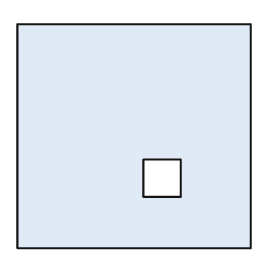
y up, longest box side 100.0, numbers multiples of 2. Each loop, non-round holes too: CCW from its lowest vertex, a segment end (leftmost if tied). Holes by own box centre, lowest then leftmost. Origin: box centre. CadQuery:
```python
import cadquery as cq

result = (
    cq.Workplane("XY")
    .moveTo(-50.0, -48.0)
    .lineTo(50.0, -48.0)
    .lineTo(50.0, 48.0)
    .lineTo(-50.0, 48.0)
    .close()
    .moveTo(4.0, -26.0)
    .lineTo(20.0, -26.0)
    .lineTo(20.0, -10.0)
    .lineTo(4.0, -10.0)
    .close()
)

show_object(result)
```